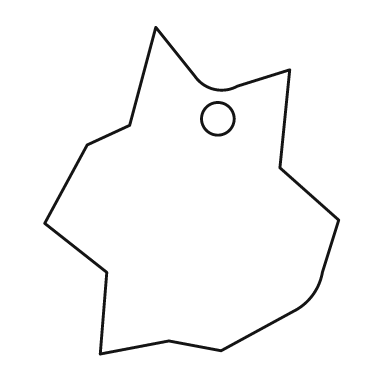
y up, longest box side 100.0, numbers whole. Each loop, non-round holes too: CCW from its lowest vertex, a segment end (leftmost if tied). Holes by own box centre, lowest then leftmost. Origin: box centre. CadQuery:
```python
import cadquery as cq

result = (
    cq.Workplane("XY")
    .moveTo(-28.0, -50.0)
    .lineTo(-7.0, -46.0)
    .lineTo(9.0, -49.0)
    .lineTo(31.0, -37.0)
    .threePointArc((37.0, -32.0), (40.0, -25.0))
    .lineTo(45.0, -9.0)
    .lineTo(27.0, 7.0)
    .lineTo(30.0, 37.0)
    .lineTo(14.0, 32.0)
    .threePointArc((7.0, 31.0), (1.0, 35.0))
    .lineTo(-11.0, 50.0)
    .lineTo(-19.0, 20.0)
    .lineTo(-32.0, 14.0)
    .lineTo(-45.0, -10.0)
    .lineTo(-26.0, -25.0)
    .close()
    .moveTo(8.0, 22.0)
    .circle(5.0)
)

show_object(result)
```